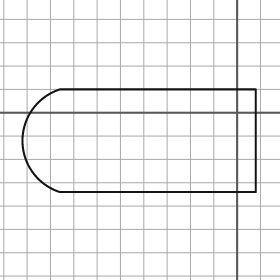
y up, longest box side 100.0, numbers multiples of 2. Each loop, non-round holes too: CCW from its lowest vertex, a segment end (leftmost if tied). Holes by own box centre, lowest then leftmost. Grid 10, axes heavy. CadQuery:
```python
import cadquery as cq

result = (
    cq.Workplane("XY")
    .moveTo(-76.0, -34.0)
    .lineTo(8.0, -34.0)
    .lineTo(8.0, 10.0)
    .lineTo(-76.0, 10.0)
    .threePointArc((-92.0, -12.0), (-76.0, -34.0))
    .close()
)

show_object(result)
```